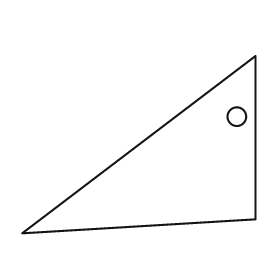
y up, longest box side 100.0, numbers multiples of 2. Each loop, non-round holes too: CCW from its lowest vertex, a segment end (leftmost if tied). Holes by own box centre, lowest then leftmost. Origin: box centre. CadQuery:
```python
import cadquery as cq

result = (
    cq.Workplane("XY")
    .moveTo(-50.0, -38.0)
    .lineTo(50.0, -32.0)
    .lineTo(50.0, 38.0)
    .close()
    .moveTo(42.0, 12.0)
    .circle(4.0)
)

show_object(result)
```